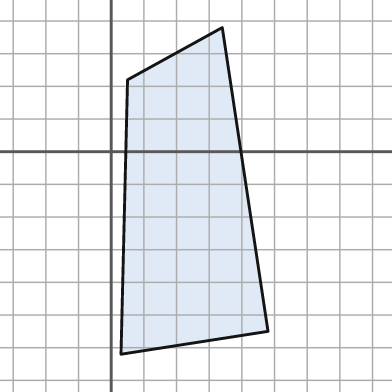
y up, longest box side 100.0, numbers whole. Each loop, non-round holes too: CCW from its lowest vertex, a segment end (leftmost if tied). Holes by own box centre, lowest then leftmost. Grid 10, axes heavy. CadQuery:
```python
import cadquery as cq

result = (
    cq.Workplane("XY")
    .moveTo(3.0, -62.0)
    .lineTo(48.0, -55.0)
    .lineTo(34.0, 38.0)
    .lineTo(5.0, 22.0)
    .close()
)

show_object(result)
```